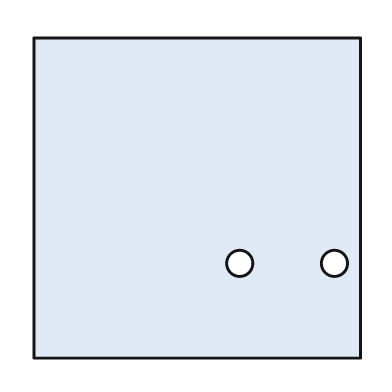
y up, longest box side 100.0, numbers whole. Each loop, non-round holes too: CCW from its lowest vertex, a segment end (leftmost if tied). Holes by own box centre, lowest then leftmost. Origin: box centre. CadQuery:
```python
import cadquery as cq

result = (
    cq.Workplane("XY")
    .moveTo(-50.0, -49.0)
    .lineTo(50.0, -49.0)
    .lineTo(50.0, 49.0)
    .lineTo(-50.0, 49.0)
    .close()
    .moveTo(13.0, -20.0)
    .circle(4.0)
    .moveTo(42.0, -20.0)
    .circle(4.0)
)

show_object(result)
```